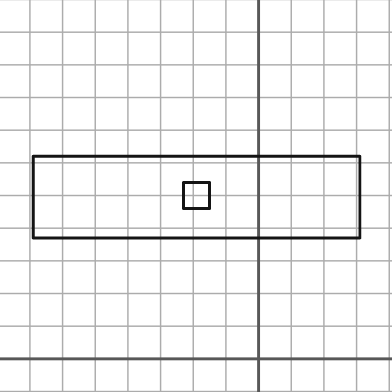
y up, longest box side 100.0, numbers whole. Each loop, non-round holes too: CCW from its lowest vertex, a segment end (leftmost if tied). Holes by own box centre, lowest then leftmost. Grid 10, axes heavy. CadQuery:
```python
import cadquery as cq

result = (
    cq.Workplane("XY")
    .moveTo(-69.0, 37.0)
    .lineTo(31.0, 37.0)
    .lineTo(31.0, 62.0)
    .lineTo(-69.0, 62.0)
    .close()
    .moveTo(-23.0, 46.0)
    .lineTo(-15.0, 46.0)
    .lineTo(-15.0, 54.0)
    .lineTo(-23.0, 54.0)
    .close()
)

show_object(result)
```